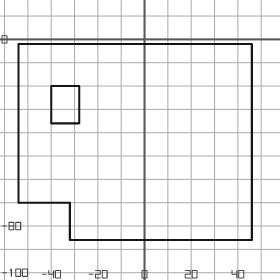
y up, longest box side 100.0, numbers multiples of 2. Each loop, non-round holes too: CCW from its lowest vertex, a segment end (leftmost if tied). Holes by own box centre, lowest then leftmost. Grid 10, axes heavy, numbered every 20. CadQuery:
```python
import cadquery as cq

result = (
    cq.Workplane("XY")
    .moveTo(-32.0, -86.0)
    .lineTo(46.0, -86.0)
    .lineTo(46.0, -2.0)
    .lineTo(-54.0, -2.0)
    .lineTo(-54.0, -70.0)
    .lineTo(-32.0, -70.0)
    .close()
    .moveTo(-40.0, -36.0)
    .lineTo(-28.0, -36.0)
    .lineTo(-28.0, -20.0)
    .lineTo(-40.0, -20.0)
    .close()
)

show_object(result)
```